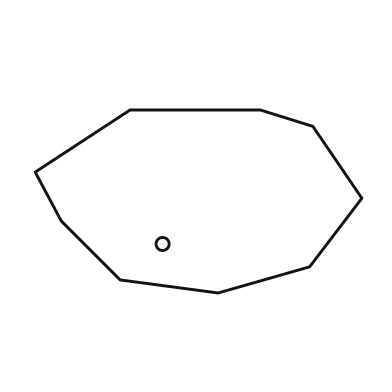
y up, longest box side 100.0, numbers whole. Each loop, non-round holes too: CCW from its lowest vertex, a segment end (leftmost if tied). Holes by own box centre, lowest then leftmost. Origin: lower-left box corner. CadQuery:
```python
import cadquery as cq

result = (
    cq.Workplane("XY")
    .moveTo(56.0, 0.0)
    .lineTo(84.0, 8.0)
    .lineTo(100.0, 29.0)
    .lineTo(85.0, 51.0)
    .lineTo(69.0, 56.0)
    .lineTo(29.0, 56.0)
    .lineTo(0.0, 37.0)
    .lineTo(8.0, 22.0)
    .lineTo(26.0, 4.0)
    .close()
    .moveTo(39.0, 15.0)
    .circle(2.0)
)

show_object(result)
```